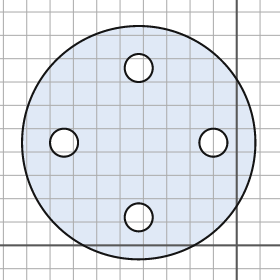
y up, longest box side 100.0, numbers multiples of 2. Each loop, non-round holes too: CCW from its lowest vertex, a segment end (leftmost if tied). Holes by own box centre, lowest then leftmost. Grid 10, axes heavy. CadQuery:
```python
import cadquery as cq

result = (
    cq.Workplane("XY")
    .moveTo(-42.0, 44.0)
    .circle(50.0)
    .moveTo(-42.0, 12.0)
    .circle(6.0)
    .moveTo(-74.0, 44.0)
    .circle(6.0)
    .moveTo(-10.0, 44.0)
    .circle(6.0)
    .moveTo(-42.0, 76.0)
    .circle(6.0)
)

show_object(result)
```